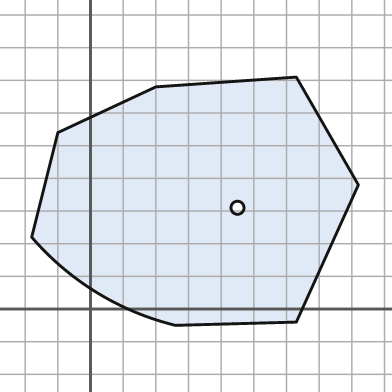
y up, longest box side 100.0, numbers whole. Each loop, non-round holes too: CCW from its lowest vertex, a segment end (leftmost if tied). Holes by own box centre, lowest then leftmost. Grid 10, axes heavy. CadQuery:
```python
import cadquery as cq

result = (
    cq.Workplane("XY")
    .moveTo(26.0, -5.0)
    .lineTo(63.0, -4.0)
    .lineTo(82.0, 38.0)
    .lineTo(63.0, 71.0)
    .lineTo(20.0, 68.0)
    .lineTo(-10.0, 54.0)
    .lineTo(-18.0, 22.0)
    .threePointArc((2.0, 5.0), (26.0, -5.0))
    .close()
    .moveTo(45.0, 31.0)
    .circle(2.0)
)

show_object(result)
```